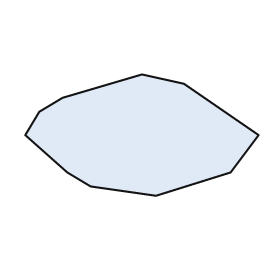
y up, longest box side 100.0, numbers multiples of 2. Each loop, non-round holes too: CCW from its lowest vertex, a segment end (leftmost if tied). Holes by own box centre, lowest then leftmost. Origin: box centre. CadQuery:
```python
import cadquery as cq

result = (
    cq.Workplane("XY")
    .moveTo(6.0, -26.0)
    .lineTo(38.0, -16.0)
    .lineTo(50.0, 0.0)
    .lineTo(18.0, 22.0)
    .lineTo(0.0, 26.0)
    .lineTo(-34.0, 16.0)
    .lineTo(-44.0, 10.0)
    .lineTo(-50.0, 0.0)
    .lineTo(-32.0, -16.0)
    .lineTo(-22.0, -22.0)
    .close()
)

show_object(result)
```